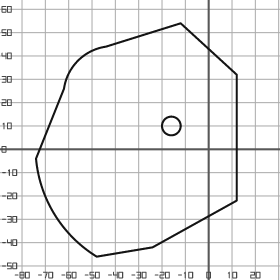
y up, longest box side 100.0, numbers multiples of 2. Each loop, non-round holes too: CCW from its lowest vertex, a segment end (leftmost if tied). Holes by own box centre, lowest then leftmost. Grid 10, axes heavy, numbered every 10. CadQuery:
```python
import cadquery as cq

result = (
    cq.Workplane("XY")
    .moveTo(-48.0, -46.0)
    .lineTo(-24.0, -42.0)
    .lineTo(12.0, -22.0)
    .lineTo(12.0, 32.0)
    .lineTo(-12.0, 54.0)
    .lineTo(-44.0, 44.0)
    .threePointArc((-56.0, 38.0), (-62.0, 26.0))
    .lineTo(-74.0, -4.0)
    .threePointArc((-66.0, -28.0), (-48.0, -46.0))
    .close()
    .moveTo(-16.0, 10.0)
    .circle(4.0)
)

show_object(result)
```